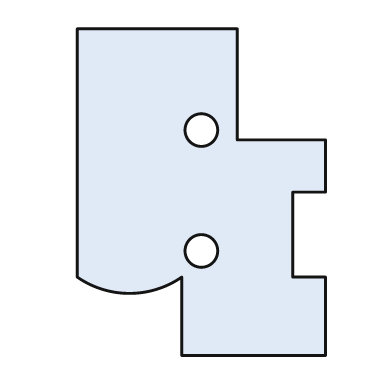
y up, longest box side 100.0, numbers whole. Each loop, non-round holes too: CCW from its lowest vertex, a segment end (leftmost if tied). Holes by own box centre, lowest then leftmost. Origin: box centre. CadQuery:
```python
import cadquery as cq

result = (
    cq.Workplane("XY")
    .moveTo(-6.0, -50.0)
    .lineTo(38.0, -50.0)
    .lineTo(38.0, -26.0)
    .lineTo(28.0, -26.0)
    .lineTo(28.0, 0.0)
    .lineTo(38.0, 0.0)
    .lineTo(38.0, 16.0)
    .lineTo(11.0, 16.0)
    .lineTo(11.0, 50.0)
    .lineTo(-38.0, 50.0)
    .lineTo(-38.0, -26.0)
    .threePointArc((-22.0, -31.0), (-6.0, -26.0))
    .close()
    .moveTo(0.0, -18.0)
    .circle(5.0)
    .moveTo(0.0, 19.0)
    .circle(5.0)
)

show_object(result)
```